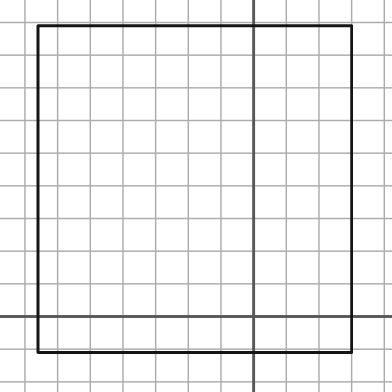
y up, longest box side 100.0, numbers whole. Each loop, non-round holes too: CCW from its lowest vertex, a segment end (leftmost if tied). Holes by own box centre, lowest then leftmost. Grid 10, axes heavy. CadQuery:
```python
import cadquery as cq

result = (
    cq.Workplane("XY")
    .moveTo(-66.0, -11.0)
    .lineTo(30.0, -11.0)
    .lineTo(30.0, 89.0)
    .lineTo(-66.0, 89.0)
    .close()
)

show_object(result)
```